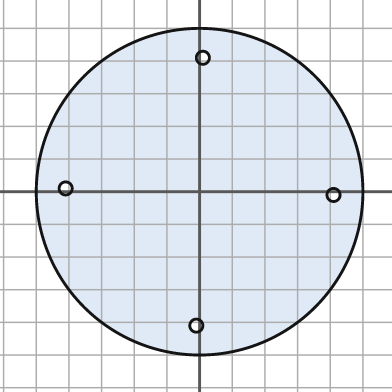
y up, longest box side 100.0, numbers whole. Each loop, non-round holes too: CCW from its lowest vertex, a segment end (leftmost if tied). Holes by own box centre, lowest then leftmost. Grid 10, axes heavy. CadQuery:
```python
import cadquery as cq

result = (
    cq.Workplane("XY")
    .moveTo(0.0, 0.0)
    .circle(50.0)
    .moveTo(-1.0, -41.0)
    .circle(2.0)
    .moveTo(41.0, -1.0)
    .circle(2.0)
    .moveTo(-41.0, 1.0)
    .circle(2.0)
    .moveTo(1.0, 41.0)
    .circle(2.0)
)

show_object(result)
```